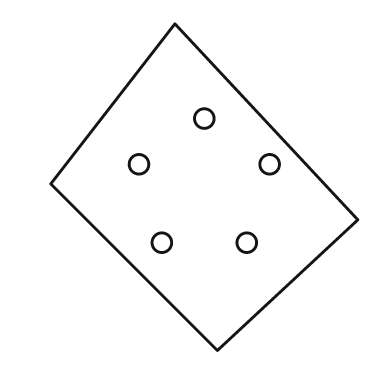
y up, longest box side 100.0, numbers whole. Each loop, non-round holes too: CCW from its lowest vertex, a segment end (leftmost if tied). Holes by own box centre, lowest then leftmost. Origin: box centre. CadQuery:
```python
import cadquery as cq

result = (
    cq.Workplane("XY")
    .moveTo(4.0, -50.0)
    .lineTo(47.0, -10.0)
    .lineTo(-9.0, 50.0)
    .lineTo(-47.0, 1.0)
    .close()
    .moveTo(-13.0, -17.0)
    .circle(3.0)
    .moveTo(13.0, -17.0)
    .circle(3.0)
    .moveTo(-20.0, 7.0)
    .circle(3.0)
    .moveTo(20.0, 7.0)
    .circle(3.0)
    .moveTo(0.0, 21.0)
    .circle(3.0)
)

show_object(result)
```